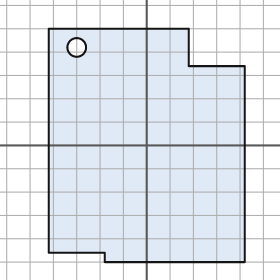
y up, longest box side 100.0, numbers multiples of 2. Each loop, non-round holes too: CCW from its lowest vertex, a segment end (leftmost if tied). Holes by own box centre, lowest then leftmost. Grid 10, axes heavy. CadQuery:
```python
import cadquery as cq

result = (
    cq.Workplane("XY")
    .moveTo(-18.0, -50.0)
    .lineTo(42.0, -50.0)
    .lineTo(42.0, 34.0)
    .lineTo(18.0, 34.0)
    .lineTo(18.0, 50.0)
    .lineTo(-42.0, 50.0)
    .lineTo(-42.0, -46.0)
    .lineTo(-18.0, -46.0)
    .close()
    .moveTo(-30.0, 42.0)
    .circle(4.0)
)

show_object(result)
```